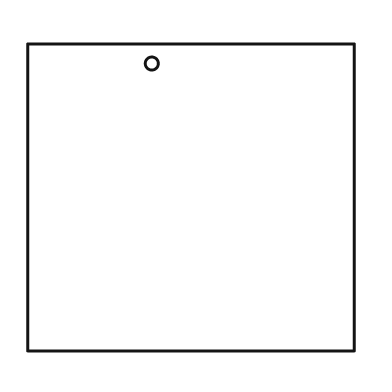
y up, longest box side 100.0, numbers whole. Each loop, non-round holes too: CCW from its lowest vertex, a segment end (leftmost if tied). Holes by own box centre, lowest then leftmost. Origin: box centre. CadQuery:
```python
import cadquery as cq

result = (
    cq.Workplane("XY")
    .moveTo(-50.0, -47.0)
    .lineTo(50.0, -47.0)
    .lineTo(50.0, 47.0)
    .lineTo(-50.0, 47.0)
    .close()
    .moveTo(-12.0, 41.0)
    .circle(2.0)
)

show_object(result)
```